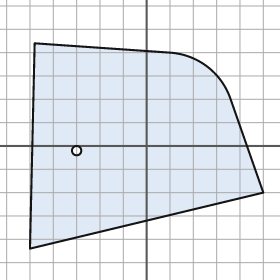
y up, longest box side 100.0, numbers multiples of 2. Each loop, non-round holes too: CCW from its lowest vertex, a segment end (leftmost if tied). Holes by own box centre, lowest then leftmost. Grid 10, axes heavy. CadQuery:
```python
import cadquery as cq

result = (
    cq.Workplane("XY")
    .moveTo(-50.0, -44.0)
    .lineTo(50.0, -20.0)
    .lineTo(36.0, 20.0)
    .threePointArc((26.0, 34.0), (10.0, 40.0))
    .lineTo(-48.0, 44.0)
    .close()
    .moveTo(-30.0, -2.0)
    .circle(2.0)
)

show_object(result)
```